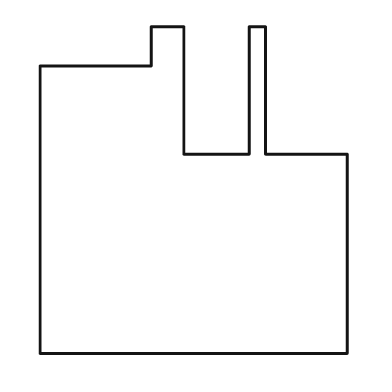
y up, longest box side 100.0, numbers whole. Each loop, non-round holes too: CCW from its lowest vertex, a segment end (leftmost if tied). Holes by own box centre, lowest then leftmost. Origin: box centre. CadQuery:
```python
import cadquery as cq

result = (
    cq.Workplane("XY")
    .moveTo(-47.0, -50.0)
    .lineTo(47.0, -50.0)
    .lineTo(47.0, 11.0)
    .lineTo(22.0, 11.0)
    .lineTo(22.0, 50.0)
    .lineTo(17.0, 50.0)
    .lineTo(17.0, 11.0)
    .lineTo(-3.0, 11.0)
    .lineTo(-3.0, 50.0)
    .lineTo(-13.0, 50.0)
    .lineTo(-13.0, 38.0)
    .lineTo(-47.0, 38.0)
    .close()
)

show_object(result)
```